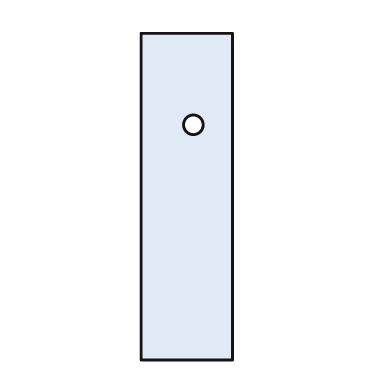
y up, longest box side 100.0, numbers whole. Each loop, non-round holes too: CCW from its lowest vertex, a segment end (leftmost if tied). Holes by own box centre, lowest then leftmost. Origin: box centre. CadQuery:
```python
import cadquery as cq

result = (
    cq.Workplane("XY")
    .moveTo(-14.0, -50.0)
    .lineTo(14.0, -50.0)
    .lineTo(14.0, 50.0)
    .lineTo(-14.0, 50.0)
    .close()
    .moveTo(2.0, 22.0)
    .circle(3.0)
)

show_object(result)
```